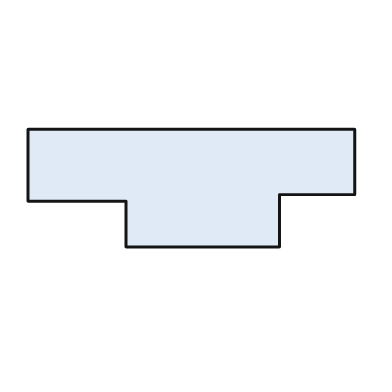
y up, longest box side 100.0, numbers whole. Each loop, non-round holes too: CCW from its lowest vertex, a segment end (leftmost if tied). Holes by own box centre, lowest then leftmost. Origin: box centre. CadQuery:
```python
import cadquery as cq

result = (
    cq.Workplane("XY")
    .moveTo(-20.0, -18.0)
    .lineTo(27.0, -18.0)
    .lineTo(27.0, -2.0)
    .lineTo(50.0, -2.0)
    .lineTo(50.0, 18.0)
    .lineTo(-50.0, 18.0)
    .lineTo(-50.0, -4.0)
    .lineTo(-20.0, -4.0)
    .close()
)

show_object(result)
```